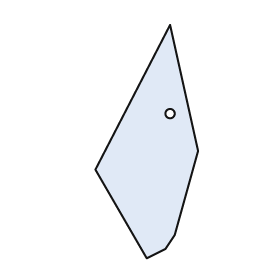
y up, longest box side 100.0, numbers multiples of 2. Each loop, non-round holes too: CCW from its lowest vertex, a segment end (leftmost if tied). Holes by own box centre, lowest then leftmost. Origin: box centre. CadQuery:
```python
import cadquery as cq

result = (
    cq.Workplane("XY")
    .moveTo(0.0, -50.0)
    .lineTo(8.0, -46.0)
    .lineTo(12.0, -40.0)
    .lineTo(22.0, -4.0)
    .lineTo(10.0, 50.0)
    .lineTo(-22.0, -12.0)
    .close()
    .moveTo(10.0, 12.0)
    .circle(2.0)
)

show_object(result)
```